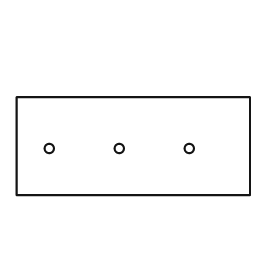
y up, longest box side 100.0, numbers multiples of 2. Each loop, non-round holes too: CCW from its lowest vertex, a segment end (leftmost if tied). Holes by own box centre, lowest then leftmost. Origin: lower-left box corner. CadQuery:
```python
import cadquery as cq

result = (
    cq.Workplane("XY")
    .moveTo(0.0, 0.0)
    .lineTo(100.0, 0.0)
    .lineTo(100.0, 42.0)
    .lineTo(0.0, 42.0)
    .close()
    .moveTo(14.0, 20.0)
    .circle(2.0)
    .moveTo(44.0, 20.0)
    .circle(2.0)
    .moveTo(74.0, 20.0)
    .circle(2.0)
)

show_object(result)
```